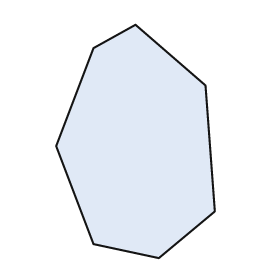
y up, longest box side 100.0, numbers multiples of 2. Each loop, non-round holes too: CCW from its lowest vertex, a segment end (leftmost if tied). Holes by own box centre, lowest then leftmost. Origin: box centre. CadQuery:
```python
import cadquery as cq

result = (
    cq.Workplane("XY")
    .moveTo(10.0, -50.0)
    .lineTo(34.0, -30.0)
    .lineTo(30.0, 24.0)
    .lineTo(0.0, 50.0)
    .lineTo(-18.0, 40.0)
    .lineTo(-34.0, -2.0)
    .lineTo(-18.0, -44.0)
    .close()
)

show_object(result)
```